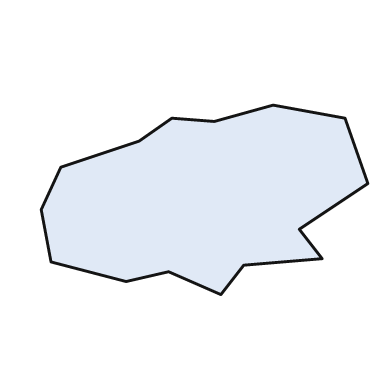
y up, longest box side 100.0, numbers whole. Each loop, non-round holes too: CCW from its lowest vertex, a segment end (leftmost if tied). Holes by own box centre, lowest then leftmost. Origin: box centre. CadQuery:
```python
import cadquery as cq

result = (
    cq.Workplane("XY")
    .moveTo(5.0, -29.0)
    .lineTo(12.0, -20.0)
    .lineTo(36.0, -18.0)
    .lineTo(29.0, -9.0)
    .lineTo(50.0, 5.0)
    .lineTo(43.0, 25.0)
    .lineTo(21.0, 29.0)
    .lineTo(3.0, 24.0)
    .lineTo(-10.0, 25.0)
    .lineTo(-20.0, 18.0)
    .lineTo(-44.0, 10.0)
    .lineTo(-50.0, -3.0)
    .lineTo(-47.0, -19.0)
    .lineTo(-24.0, -25.0)
    .lineTo(-11.0, -22.0)
    .close()
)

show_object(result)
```